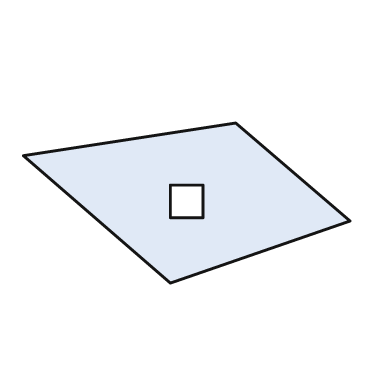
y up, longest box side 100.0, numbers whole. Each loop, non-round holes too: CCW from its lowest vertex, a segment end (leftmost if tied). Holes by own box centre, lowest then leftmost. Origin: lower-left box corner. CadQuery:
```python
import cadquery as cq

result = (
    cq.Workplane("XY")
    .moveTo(45.0, 0.0)
    .lineTo(100.0, 19.0)
    .lineTo(65.0, 49.0)
    .lineTo(0.0, 39.0)
    .close()
    .moveTo(45.0, 20.0)
    .lineTo(55.0, 20.0)
    .lineTo(55.0, 30.0)
    .lineTo(45.0, 30.0)
    .close()
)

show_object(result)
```